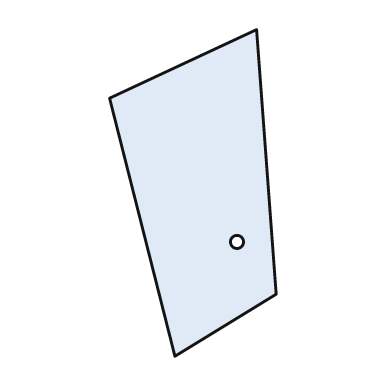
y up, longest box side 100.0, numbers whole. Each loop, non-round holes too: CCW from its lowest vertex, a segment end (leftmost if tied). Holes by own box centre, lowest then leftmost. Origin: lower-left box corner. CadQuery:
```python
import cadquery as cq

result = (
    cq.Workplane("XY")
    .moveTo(20.0, 0.0)
    .lineTo(51.0, 19.0)
    .lineTo(45.0, 100.0)
    .lineTo(0.0, 79.0)
    .close()
    .moveTo(39.0, 35.0)
    .circle(2.0)
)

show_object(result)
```